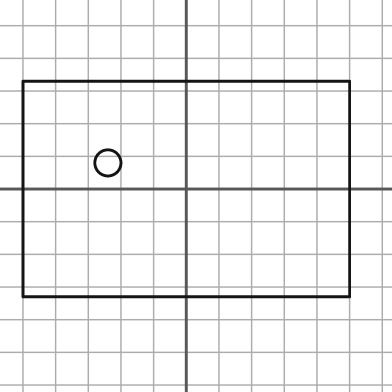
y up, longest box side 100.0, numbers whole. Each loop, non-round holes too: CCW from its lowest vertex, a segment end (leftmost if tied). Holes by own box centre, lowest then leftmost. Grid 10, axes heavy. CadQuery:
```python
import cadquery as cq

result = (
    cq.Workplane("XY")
    .moveTo(-50.0, -33.0)
    .lineTo(50.0, -33.0)
    .lineTo(50.0, 33.0)
    .lineTo(-50.0, 33.0)
    .close()
    .moveTo(-24.0, 8.0)
    .circle(4.0)
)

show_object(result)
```